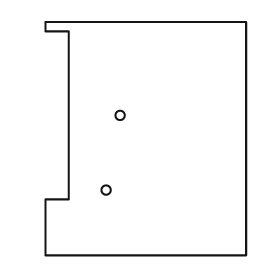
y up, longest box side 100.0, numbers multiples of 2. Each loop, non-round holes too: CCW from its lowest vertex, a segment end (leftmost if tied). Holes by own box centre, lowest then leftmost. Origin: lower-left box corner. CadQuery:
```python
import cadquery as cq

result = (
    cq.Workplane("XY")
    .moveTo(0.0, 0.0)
    .lineTo(86.0, 0.0)
    .lineTo(86.0, 100.0)
    .lineTo(0.0, 100.0)
    .lineTo(0.0, 96.0)
    .lineTo(10.0, 96.0)
    .lineTo(10.0, 24.0)
    .lineTo(0.0, 24.0)
    .close()
    .moveTo(26.0, 28.0)
    .circle(2.0)
    .moveTo(32.0, 60.0)
    .circle(2.0)
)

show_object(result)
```